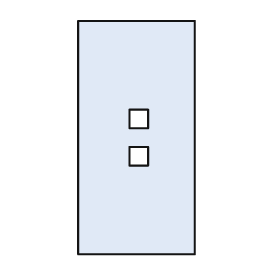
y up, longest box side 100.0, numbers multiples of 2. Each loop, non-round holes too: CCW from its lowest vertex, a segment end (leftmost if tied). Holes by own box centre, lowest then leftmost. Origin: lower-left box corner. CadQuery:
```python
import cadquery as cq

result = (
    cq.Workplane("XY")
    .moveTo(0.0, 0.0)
    .lineTo(50.0, 0.0)
    .lineTo(50.0, 100.0)
    .lineTo(0.0, 100.0)
    .close()
    .moveTo(22.0, 38.0)
    .lineTo(30.0, 38.0)
    .lineTo(30.0, 46.0)
    .lineTo(22.0, 46.0)
    .close()
    .moveTo(22.0, 54.0)
    .lineTo(30.0, 54.0)
    .lineTo(30.0, 62.0)
    .lineTo(22.0, 62.0)
    .close()
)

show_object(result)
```